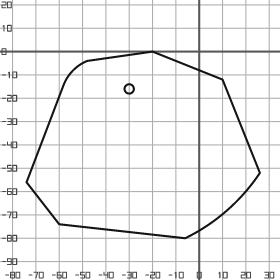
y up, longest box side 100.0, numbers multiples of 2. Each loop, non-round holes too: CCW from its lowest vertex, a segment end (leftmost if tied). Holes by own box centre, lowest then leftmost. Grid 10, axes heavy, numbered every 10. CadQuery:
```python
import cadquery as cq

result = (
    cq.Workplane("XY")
    .moveTo(-6.0, -80.0)
    .threePointArc((12.0, -68.0), (26.0, -52.0))
    .lineTo(10.0, -12.0)
    .lineTo(-20.0, 0.0)
    .lineTo(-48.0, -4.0)
    .threePointArc((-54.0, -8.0), (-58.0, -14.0))
    .lineTo(-74.0, -56.0)
    .lineTo(-60.0, -74.0)
    .close()
    .moveTo(-30.0, -16.0)
    .circle(2.0)
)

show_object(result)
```